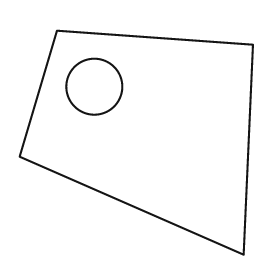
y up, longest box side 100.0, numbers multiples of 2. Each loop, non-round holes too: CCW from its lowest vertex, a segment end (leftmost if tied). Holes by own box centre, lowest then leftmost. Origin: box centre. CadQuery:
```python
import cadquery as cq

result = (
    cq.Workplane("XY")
    .moveTo(46.0, -48.0)
    .lineTo(50.0, 42.0)
    .lineTo(-34.0, 48.0)
    .lineTo(-50.0, -6.0)
    .close()
    .moveTo(-18.0, 24.0)
    .circle(12.0)
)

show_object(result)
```